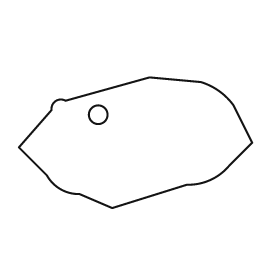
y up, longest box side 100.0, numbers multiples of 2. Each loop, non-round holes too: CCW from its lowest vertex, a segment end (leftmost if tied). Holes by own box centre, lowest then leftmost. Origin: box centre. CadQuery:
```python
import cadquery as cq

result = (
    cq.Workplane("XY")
    .moveTo(-10.0, -28.0)
    .lineTo(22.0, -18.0)
    .threePointArc((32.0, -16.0), (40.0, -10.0))
    .lineTo(50.0, 0.0)
    .lineTo(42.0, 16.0)
    .threePointArc((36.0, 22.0), (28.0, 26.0))
    .lineTo(6.0, 28.0)
    .lineTo(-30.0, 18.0)
    .threePointArc((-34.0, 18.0), (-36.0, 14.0))
    .lineTo(-50.0, -2.0)
    .lineTo(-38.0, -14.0)
    .threePointArc((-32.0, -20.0), (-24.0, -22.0))
    .close()
    .moveTo(-16.0, 12.0)
    .circle(4.0)
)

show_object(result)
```